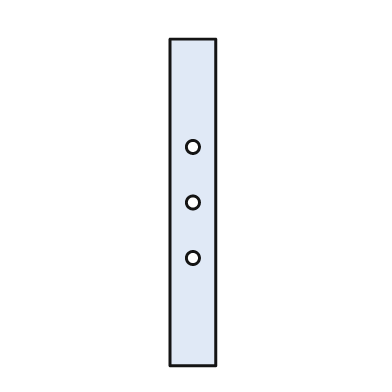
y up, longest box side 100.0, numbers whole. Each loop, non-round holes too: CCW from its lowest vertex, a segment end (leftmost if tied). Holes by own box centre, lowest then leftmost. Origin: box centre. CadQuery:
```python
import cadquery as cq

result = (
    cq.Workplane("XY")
    .moveTo(-7.0, -50.0)
    .lineTo(7.0, -50.0)
    .lineTo(7.0, 50.0)
    .lineTo(-7.0, 50.0)
    .close()
    .moveTo(0.0, -17.0)
    .circle(2.0)
    .moveTo(0.0, 0.0)
    .circle(2.0)
    .moveTo(0.0, 17.0)
    .circle(2.0)
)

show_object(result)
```